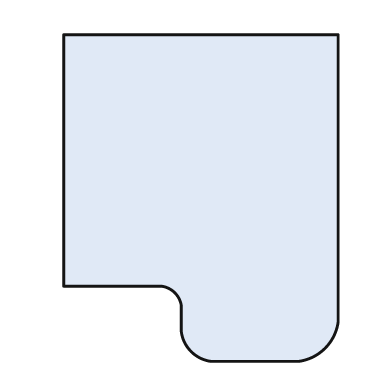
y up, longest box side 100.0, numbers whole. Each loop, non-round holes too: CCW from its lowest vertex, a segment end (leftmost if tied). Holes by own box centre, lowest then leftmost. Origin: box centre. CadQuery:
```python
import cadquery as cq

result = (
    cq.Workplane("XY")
    .moveTo(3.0, -50.0)
    .lineTo(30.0, -50.0)
    .threePointArc((38.0, -46.0), (42.0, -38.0))
    .lineTo(42.0, 50.0)
    .lineTo(-42.0, 50.0)
    .lineTo(-42.0, -27.0)
    .lineTo(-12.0, -27.0)
    .threePointArc((-8.0, -29.0), (-6.0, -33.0))
    .lineTo(-6.0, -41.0)
    .threePointArc((-3.0, -47.0), (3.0, -50.0))
    .close()
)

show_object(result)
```